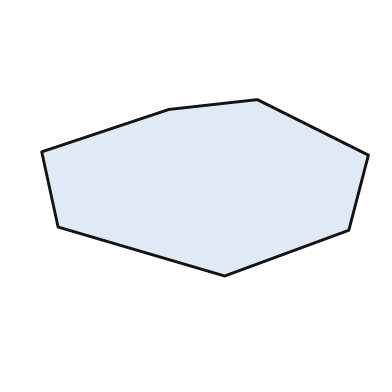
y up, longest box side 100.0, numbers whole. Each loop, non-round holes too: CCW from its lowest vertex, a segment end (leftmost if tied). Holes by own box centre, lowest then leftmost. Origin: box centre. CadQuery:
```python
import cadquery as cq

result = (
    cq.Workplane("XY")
    .moveTo(6.0, -27.0)
    .lineTo(44.0, -13.0)
    .lineTo(50.0, 10.0)
    .lineTo(16.0, 27.0)
    .lineTo(-11.0, 24.0)
    .lineTo(-50.0, 11.0)
    .lineTo(-45.0, -12.0)
    .close()
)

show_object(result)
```